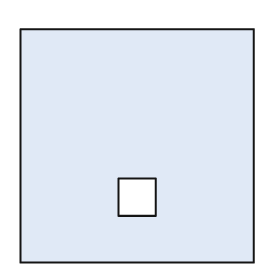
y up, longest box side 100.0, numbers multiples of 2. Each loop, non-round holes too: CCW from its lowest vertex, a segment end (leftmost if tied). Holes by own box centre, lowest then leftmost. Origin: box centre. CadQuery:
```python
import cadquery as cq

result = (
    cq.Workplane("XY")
    .moveTo(-50.0, -50.0)
    .lineTo(50.0, -50.0)
    .lineTo(50.0, 50.0)
    .lineTo(-50.0, 50.0)
    .close()
    .moveTo(-8.0, -30.0)
    .lineTo(8.0, -30.0)
    .lineTo(8.0, -14.0)
    .lineTo(-8.0, -14.0)
    .close()
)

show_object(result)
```